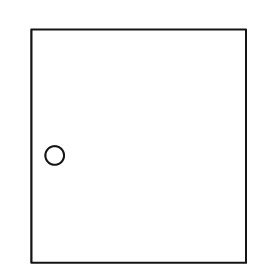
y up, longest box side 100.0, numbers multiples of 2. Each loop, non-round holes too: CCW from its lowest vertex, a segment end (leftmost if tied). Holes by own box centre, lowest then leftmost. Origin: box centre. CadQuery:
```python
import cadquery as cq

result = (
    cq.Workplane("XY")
    .moveTo(-46.0, -50.0)
    .lineTo(46.0, -50.0)
    .lineTo(46.0, 50.0)
    .lineTo(-46.0, 50.0)
    .close()
    .moveTo(-36.0, -4.0)
    .circle(4.0)
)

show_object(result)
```